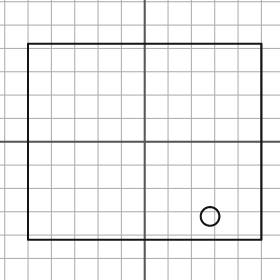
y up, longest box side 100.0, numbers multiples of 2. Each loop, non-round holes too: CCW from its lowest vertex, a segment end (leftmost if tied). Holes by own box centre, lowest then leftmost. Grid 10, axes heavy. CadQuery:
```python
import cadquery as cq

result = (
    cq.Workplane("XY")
    .moveTo(-50.0, -42.0)
    .lineTo(50.0, -42.0)
    .lineTo(50.0, 42.0)
    .lineTo(-50.0, 42.0)
    .close()
    .moveTo(28.0, -32.0)
    .circle(4.0)
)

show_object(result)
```